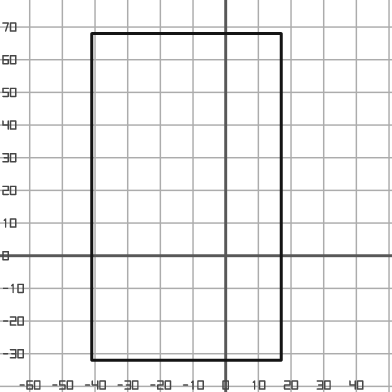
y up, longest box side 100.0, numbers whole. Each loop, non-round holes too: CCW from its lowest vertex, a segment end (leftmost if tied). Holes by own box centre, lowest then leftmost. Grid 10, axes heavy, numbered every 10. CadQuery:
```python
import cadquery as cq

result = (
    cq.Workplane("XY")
    .moveTo(-41.0, -32.0)
    .lineTo(17.0, -32.0)
    .lineTo(17.0, 68.0)
    .lineTo(-41.0, 68.0)
    .close()
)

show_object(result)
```